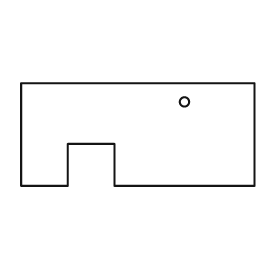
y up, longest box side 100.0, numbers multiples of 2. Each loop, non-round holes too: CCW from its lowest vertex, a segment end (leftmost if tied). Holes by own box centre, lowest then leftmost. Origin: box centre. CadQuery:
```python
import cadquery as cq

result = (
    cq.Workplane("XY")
    .moveTo(-50.0, -22.0)
    .lineTo(-30.0, -22.0)
    .lineTo(-30.0, -4.0)
    .lineTo(-10.0, -4.0)
    .lineTo(-10.0, -22.0)
    .lineTo(50.0, -22.0)
    .lineTo(50.0, 22.0)
    .lineTo(-50.0, 22.0)
    .close()
    .moveTo(20.0, 14.0)
    .circle(2.0)
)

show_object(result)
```